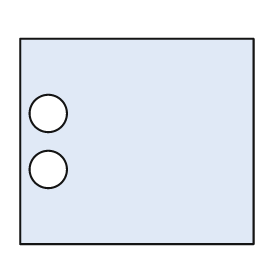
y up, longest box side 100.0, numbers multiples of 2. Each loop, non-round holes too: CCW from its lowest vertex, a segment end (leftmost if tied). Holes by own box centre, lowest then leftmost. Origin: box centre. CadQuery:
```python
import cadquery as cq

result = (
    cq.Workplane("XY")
    .moveTo(-50.0, -44.0)
    .lineTo(50.0, -44.0)
    .lineTo(50.0, 44.0)
    .lineTo(-50.0, 44.0)
    .close()
    .moveTo(-38.0, -12.0)
    .circle(8.0)
    .moveTo(-38.0, 12.0)
    .circle(8.0)
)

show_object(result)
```